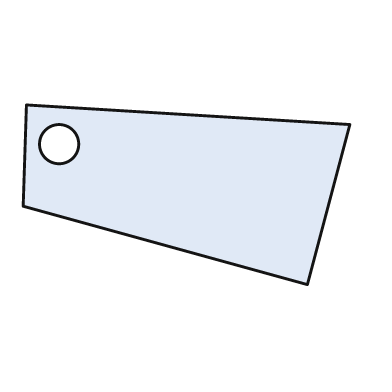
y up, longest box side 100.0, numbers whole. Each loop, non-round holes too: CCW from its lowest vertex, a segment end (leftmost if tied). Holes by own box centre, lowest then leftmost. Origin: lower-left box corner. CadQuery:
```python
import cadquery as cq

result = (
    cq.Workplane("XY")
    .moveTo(87.0, 0.0)
    .lineTo(100.0, 49.0)
    .lineTo(1.0, 55.0)
    .lineTo(0.0, 24.0)
    .close()
    .moveTo(11.0, 43.0)
    .circle(6.0)
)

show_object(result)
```